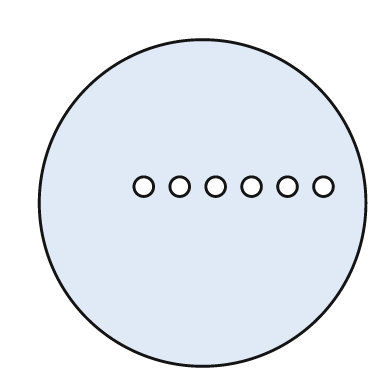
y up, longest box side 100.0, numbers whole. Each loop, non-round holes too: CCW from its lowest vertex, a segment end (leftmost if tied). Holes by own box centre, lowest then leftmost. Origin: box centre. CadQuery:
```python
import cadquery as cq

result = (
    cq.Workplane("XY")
    .moveTo(0.0, 0.0)
    .circle(50.0)
    .moveTo(-18.0, 5.0)
    .circle(3.0)
    .moveTo(-7.0, 5.0)
    .circle(3.0)
    .moveTo(4.0, 5.0)
    .circle(3.0)
    .moveTo(15.0, 5.0)
    .circle(3.0)
    .moveTo(26.0, 5.0)
    .circle(3.0)
    .moveTo(37.0, 5.0)
    .circle(3.0)
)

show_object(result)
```